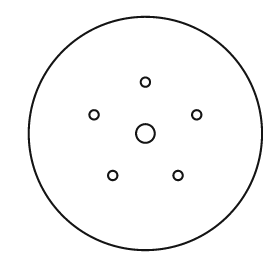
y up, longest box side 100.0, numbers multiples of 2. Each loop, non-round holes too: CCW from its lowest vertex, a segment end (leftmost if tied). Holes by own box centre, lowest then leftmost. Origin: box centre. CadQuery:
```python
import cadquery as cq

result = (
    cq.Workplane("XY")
    .moveTo(0.0, 0.0)
    .circle(50.0)
    .moveTo(-14.0, -18.0)
    .circle(2.0)
    .moveTo(14.0, -18.0)
    .circle(2.0)
    .moveTo(0.0, 0.0)
    .circle(4.0)
    .moveTo(-22.0, 8.0)
    .circle(2.0)
    .moveTo(22.0, 8.0)
    .circle(2.0)
    .moveTo(0.0, 22.0)
    .circle(2.0)
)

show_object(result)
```